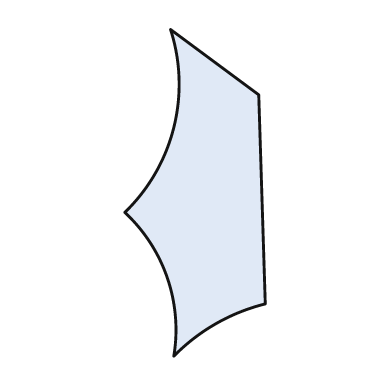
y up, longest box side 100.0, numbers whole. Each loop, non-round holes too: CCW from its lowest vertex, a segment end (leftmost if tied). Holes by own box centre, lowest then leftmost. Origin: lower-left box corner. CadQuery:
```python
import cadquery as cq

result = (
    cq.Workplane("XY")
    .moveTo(15.0, 0.0)
    .threePointArc((28.0, 10.0), (43.0, 16.0))
    .lineTo(41.0, 80.0)
    .lineTo(14.0, 100.0)
    .threePointArc((15.0, 70.0), (0.0, 44.0))
    .threePointArc((13.0, 24.0), (15.0, 0.0))
    .close()
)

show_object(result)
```